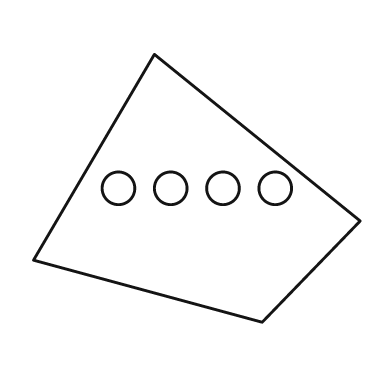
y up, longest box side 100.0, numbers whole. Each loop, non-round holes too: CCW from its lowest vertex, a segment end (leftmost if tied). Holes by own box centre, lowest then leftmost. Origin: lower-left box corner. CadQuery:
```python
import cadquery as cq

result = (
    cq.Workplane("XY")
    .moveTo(70.0, 0.0)
    .lineTo(100.0, 31.0)
    .lineTo(37.0, 82.0)
    .lineTo(0.0, 19.0)
    .close()
    .moveTo(26.0, 41.0)
    .circle(5.0)
    .moveTo(42.0, 41.0)
    .circle(5.0)
    .moveTo(58.0, 41.0)
    .circle(5.0)
    .moveTo(74.0, 41.0)
    .circle(5.0)
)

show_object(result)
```